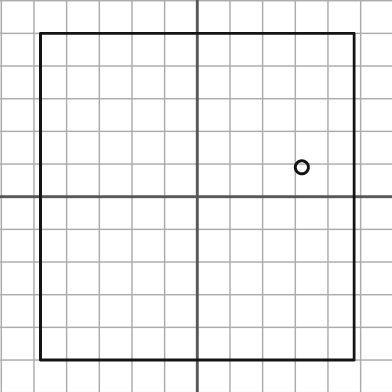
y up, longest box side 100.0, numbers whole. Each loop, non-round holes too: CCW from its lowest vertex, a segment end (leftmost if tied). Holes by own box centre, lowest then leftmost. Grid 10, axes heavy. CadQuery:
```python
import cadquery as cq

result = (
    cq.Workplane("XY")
    .moveTo(-48.0, -50.0)
    .lineTo(48.0, -50.0)
    .lineTo(48.0, 50.0)
    .lineTo(-48.0, 50.0)
    .close()
    .moveTo(32.0, 9.0)
    .circle(2.0)
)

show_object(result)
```